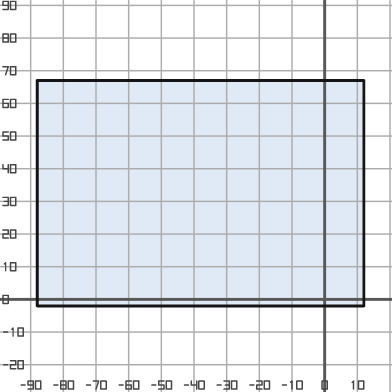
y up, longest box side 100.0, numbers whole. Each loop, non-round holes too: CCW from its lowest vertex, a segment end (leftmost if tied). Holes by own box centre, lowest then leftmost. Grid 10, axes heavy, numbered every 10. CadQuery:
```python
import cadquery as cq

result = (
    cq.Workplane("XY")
    .moveTo(-88.0, -2.0)
    .lineTo(12.0, -2.0)
    .lineTo(12.0, 67.0)
    .lineTo(-88.0, 67.0)
    .close()
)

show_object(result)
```